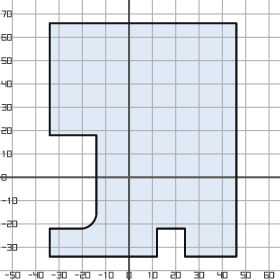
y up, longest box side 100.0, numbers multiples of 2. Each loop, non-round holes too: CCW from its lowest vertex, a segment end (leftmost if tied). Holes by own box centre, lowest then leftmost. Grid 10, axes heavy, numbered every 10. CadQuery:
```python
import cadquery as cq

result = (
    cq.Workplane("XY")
    .moveTo(-34.0, -34.0)
    .lineTo(12.0, -34.0)
    .lineTo(12.0, -22.0)
    .lineTo(24.0, -22.0)
    .lineTo(24.0, -34.0)
    .lineTo(46.0, -34.0)
    .lineTo(46.0, 66.0)
    .lineTo(-34.0, 66.0)
    .lineTo(-34.0, 18.0)
    .lineTo(-14.0, 18.0)
    .lineTo(-14.0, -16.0)
    .threePointArc((-16.0, -20.0), (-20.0, -22.0))
    .lineTo(-34.0, -22.0)
    .close()
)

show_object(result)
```